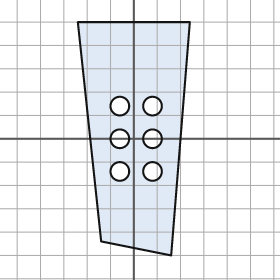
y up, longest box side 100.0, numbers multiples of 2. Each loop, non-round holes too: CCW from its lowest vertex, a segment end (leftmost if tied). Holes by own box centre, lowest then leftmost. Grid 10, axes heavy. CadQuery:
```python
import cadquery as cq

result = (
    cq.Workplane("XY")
    .moveTo(16.0, -50.0)
    .lineTo(24.0, 50.0)
    .lineTo(-24.0, 50.0)
    .lineTo(-14.0, -44.0)
    .close()
    .moveTo(-6.0, -14.0)
    .circle(4.0)
    .moveTo(8.0, -14.0)
    .circle(4.0)
    .moveTo(-6.0, 0.0)
    .circle(4.0)
    .moveTo(8.0, 0.0)
    .circle(4.0)
    .moveTo(-6.0, 14.0)
    .circle(4.0)
    .moveTo(8.0, 14.0)
    .circle(4.0)
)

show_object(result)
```